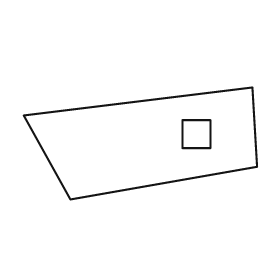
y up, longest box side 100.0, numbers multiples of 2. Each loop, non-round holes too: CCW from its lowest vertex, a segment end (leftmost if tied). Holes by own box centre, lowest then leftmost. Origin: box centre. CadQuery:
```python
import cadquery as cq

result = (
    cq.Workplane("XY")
    .moveTo(-30.0, -24.0)
    .lineTo(50.0, -10.0)
    .lineTo(48.0, 24.0)
    .lineTo(-50.0, 12.0)
    .close()
    .moveTo(18.0, -2.0)
    .lineTo(30.0, -2.0)
    .lineTo(30.0, 10.0)
    .lineTo(18.0, 10.0)
    .close()
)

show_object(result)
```